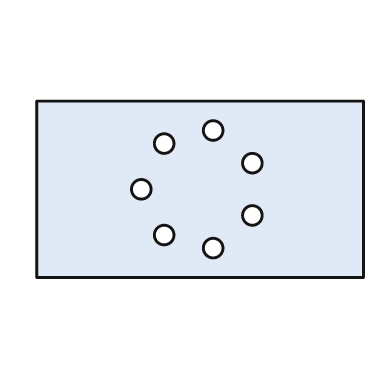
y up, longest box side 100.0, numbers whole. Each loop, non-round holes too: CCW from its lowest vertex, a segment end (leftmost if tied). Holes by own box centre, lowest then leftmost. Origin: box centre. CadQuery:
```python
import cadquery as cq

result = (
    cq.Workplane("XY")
    .moveTo(-50.0, -27.0)
    .lineTo(50.0, -27.0)
    .lineTo(50.0, 27.0)
    .lineTo(-50.0, 27.0)
    .close()
    .moveTo(4.0, -18.0)
    .circle(3.0)
    .moveTo(-11.0, -14.0)
    .circle(3.0)
    .moveTo(16.0, -8.0)
    .circle(3.0)
    .moveTo(-18.0, 0.0)
    .circle(3.0)
    .moveTo(16.0, 8.0)
    .circle(3.0)
    .moveTo(-11.0, 14.0)
    .circle(3.0)
    .moveTo(4.0, 18.0)
    .circle(3.0)
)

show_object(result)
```